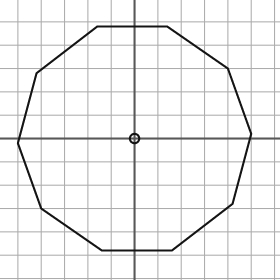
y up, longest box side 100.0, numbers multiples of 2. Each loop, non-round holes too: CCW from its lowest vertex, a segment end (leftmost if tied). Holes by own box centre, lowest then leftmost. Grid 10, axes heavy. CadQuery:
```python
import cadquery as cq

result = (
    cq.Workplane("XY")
    .moveTo(-14.0, -48.0)
    .lineTo(16.0, -48.0)
    .lineTo(42.0, -28.0)
    .lineTo(50.0, 2.0)
    .lineTo(40.0, 30.0)
    .lineTo(14.0, 48.0)
    .lineTo(-16.0, 48.0)
    .lineTo(-42.0, 28.0)
    .lineTo(-50.0, -2.0)
    .lineTo(-40.0, -30.0)
    .close()
    .moveTo(0.0, 0.0)
    .circle(2.0)
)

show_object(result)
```